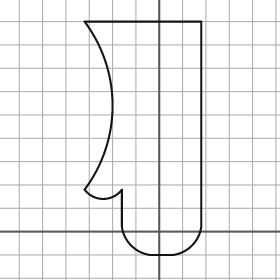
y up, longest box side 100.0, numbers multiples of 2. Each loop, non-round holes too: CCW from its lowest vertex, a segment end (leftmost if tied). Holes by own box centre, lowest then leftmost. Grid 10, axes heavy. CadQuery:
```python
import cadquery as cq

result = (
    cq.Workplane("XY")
    .moveTo(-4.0, -10.0)
    .lineTo(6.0, -10.0)
    .threePointArc((14.0, -6.0), (18.0, 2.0))
    .lineTo(18.0, 90.0)
    .lineTo(-32.0, 90.0)
    .threePointArc((-20.0, 54.0), (-32.0, 18.0))
    .threePointArc((-24.0, 14.0), (-16.0, 18.0))
    .lineTo(-16.0, 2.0)
    .threePointArc((-12.0, -6.0), (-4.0, -10.0))
    .close()
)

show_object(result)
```